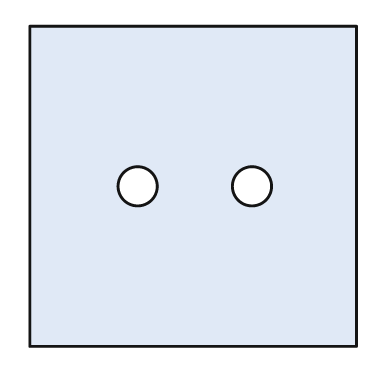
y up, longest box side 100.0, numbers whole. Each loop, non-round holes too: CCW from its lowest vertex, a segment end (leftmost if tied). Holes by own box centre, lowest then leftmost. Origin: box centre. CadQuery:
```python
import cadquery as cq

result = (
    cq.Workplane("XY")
    .moveTo(-50.0, -49.0)
    .lineTo(50.0, -49.0)
    .lineTo(50.0, 49.0)
    .lineTo(-50.0, 49.0)
    .close()
    .moveTo(-17.0, 0.0)
    .circle(6.0)
    .moveTo(18.0, 0.0)
    .circle(6.0)
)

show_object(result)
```